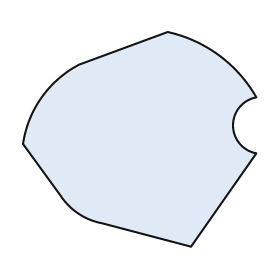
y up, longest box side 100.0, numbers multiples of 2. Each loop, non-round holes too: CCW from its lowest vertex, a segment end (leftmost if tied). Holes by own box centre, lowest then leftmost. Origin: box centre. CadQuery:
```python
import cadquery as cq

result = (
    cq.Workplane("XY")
    .moveTo(22.0, -46.0)
    .lineTo(50.0, -6.0)
    .threePointArc((40.0, 6.0), (50.0, 18.0))
    .threePointArc((34.0, 36.0), (12.0, 46.0))
    .lineTo(-26.0, 32.0)
    .threePointArc((-42.0, 18.0), (-50.0, -2.0))
    .lineTo(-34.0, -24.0)
    .threePointArc((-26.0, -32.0), (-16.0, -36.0))
    .close()
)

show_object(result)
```